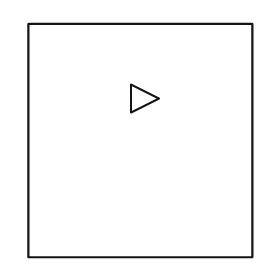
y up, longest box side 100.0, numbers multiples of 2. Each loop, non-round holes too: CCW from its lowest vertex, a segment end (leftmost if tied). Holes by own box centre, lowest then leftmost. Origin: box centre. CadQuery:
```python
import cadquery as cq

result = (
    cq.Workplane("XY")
    .moveTo(-48.0, -50.0)
    .lineTo(48.0, -50.0)
    .lineTo(48.0, 50.0)
    .lineTo(-48.0, 50.0)
    .close()
    .moveTo(-4.0, 12.0)
    .lineTo(8.0, 18.0)
    .lineTo(-4.0, 24.0)
    .close()
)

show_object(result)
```